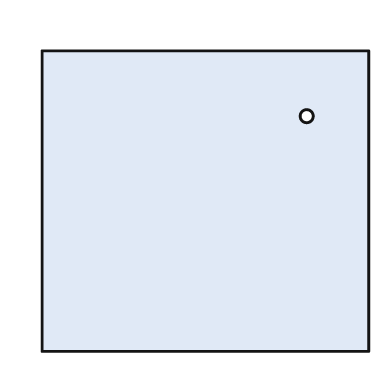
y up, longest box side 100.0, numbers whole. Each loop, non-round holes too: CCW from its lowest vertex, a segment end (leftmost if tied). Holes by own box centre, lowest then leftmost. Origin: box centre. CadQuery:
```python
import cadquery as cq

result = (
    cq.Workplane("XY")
    .moveTo(-50.0, -46.0)
    .lineTo(50.0, -46.0)
    .lineTo(50.0, 46.0)
    .lineTo(-50.0, 46.0)
    .close()
    .moveTo(31.0, 26.0)
    .circle(2.0)
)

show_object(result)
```